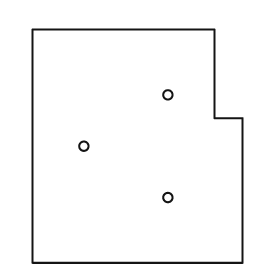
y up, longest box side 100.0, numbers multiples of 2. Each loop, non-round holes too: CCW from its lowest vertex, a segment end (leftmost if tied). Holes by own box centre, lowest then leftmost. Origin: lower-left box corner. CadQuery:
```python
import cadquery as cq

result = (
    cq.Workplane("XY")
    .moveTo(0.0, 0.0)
    .lineTo(90.0, 0.0)
    .lineTo(90.0, 62.0)
    .lineTo(78.0, 62.0)
    .lineTo(78.0, 100.0)
    .lineTo(0.0, 100.0)
    .close()
    .moveTo(58.0, 28.0)
    .circle(2.0)
    .moveTo(22.0, 50.0)
    .circle(2.0)
    .moveTo(58.0, 72.0)
    .circle(2.0)
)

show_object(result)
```